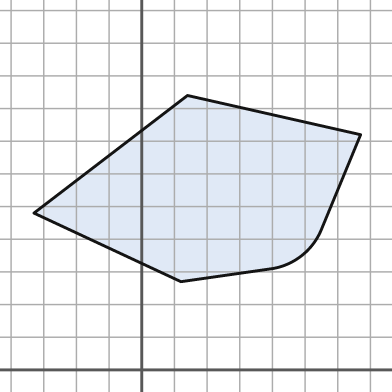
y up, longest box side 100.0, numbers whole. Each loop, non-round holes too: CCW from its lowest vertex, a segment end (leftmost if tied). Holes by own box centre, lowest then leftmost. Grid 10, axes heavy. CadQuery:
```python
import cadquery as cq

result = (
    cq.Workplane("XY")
    .moveTo(12.0, 27.0)
    .lineTo(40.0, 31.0)
    .threePointArc((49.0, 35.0), (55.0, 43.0))
    .lineTo(67.0, 72.0)
    .lineTo(14.0, 84.0)
    .lineTo(-33.0, 48.0)
    .close()
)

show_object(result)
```